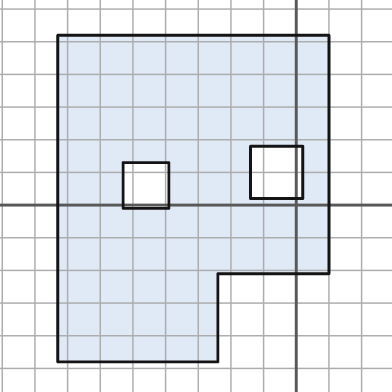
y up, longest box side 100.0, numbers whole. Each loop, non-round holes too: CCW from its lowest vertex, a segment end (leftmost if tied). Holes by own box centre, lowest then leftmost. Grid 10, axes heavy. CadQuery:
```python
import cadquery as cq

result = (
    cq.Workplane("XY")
    .moveTo(-73.0, -48.0)
    .lineTo(-24.0, -48.0)
    .lineTo(-24.0, -21.0)
    .lineTo(10.0, -21.0)
    .lineTo(10.0, 52.0)
    .lineTo(-73.0, 52.0)
    .close()
    .moveTo(-53.0, -1.0)
    .lineTo(-39.0, -1.0)
    .lineTo(-39.0, 13.0)
    .lineTo(-53.0, 13.0)
    .close()
    .moveTo(-14.0, 2.0)
    .lineTo(2.0, 2.0)
    .lineTo(2.0, 18.0)
    .lineTo(-14.0, 18.0)
    .close()
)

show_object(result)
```